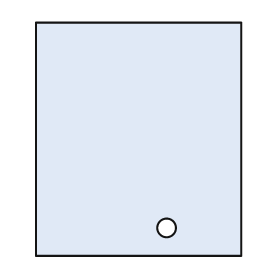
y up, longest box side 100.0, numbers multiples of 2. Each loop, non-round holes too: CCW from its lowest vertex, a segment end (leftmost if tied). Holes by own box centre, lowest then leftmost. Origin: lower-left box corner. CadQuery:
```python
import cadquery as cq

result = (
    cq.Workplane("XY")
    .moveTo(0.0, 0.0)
    .lineTo(88.0, 0.0)
    .lineTo(88.0, 100.0)
    .lineTo(0.0, 100.0)
    .close()
    .moveTo(56.0, 12.0)
    .circle(4.0)
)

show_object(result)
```